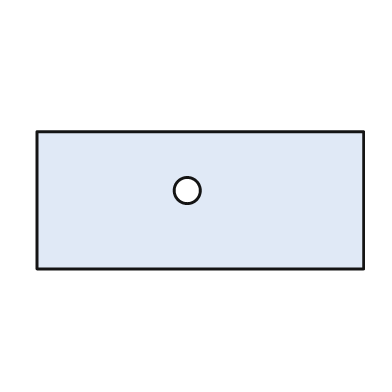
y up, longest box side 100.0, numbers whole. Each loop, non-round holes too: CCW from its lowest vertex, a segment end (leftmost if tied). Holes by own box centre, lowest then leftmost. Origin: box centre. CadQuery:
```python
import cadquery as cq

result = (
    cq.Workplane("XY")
    .moveTo(-50.0, -21.0)
    .lineTo(50.0, -21.0)
    .lineTo(50.0, 21.0)
    .lineTo(-50.0, 21.0)
    .close()
    .moveTo(-4.0, 3.0)
    .circle(4.0)
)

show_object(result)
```